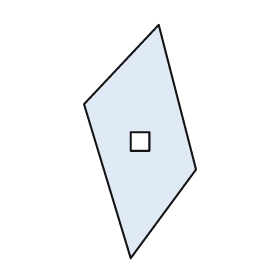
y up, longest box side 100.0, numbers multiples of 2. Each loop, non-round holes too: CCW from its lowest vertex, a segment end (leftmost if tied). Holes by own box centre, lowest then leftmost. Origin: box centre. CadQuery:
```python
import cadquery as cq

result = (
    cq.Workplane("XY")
    .moveTo(-4.0, -50.0)
    .lineTo(24.0, -12.0)
    .lineTo(8.0, 50.0)
    .lineTo(-24.0, 16.0)
    .close()
    .moveTo(-4.0, -4.0)
    .lineTo(4.0, -4.0)
    .lineTo(4.0, 4.0)
    .lineTo(-4.0, 4.0)
    .close()
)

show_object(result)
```